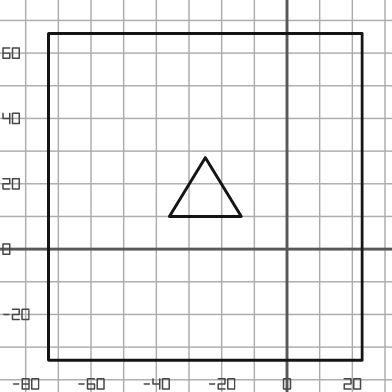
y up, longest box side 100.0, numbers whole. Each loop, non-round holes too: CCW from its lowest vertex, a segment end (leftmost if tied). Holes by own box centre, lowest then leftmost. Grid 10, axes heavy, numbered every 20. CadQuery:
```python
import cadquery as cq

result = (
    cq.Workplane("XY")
    .moveTo(-73.0, -34.0)
    .lineTo(23.0, -34.0)
    .lineTo(23.0, 66.0)
    .lineTo(-73.0, 66.0)
    .close()
    .moveTo(-36.0, 10.0)
    .lineTo(-14.0, 10.0)
    .lineTo(-25.0, 28.0)
    .close()
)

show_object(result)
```